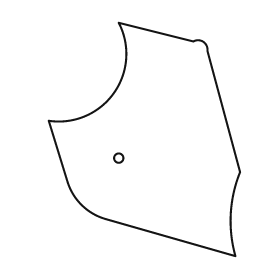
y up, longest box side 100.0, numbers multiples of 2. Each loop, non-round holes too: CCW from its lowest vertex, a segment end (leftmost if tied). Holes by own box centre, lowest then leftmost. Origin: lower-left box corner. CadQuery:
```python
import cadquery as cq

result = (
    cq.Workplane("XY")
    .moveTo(80.0, 0.0)
    .threePointArc((78.0, 18.0), (82.0, 36.0))
    .lineTo(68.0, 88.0)
    .threePointArc((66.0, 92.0), (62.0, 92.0))
    .lineTo(30.0, 100.0)
    .threePointArc((28.0, 70.0), (0.0, 58.0))
    .lineTo(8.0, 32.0)
    .threePointArc((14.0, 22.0), (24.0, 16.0))
    .close()
    .moveTo(30.0, 42.0)
    .circle(2.0)
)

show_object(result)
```